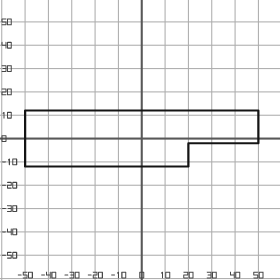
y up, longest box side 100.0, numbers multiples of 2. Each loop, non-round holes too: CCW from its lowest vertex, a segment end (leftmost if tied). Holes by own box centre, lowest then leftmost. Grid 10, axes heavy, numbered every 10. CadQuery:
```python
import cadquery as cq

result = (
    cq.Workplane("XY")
    .moveTo(-50.0, -12.0)
    .lineTo(20.0, -12.0)
    .lineTo(20.0, -2.0)
    .lineTo(50.0, -2.0)
    .lineTo(50.0, 12.0)
    .lineTo(-50.0, 12.0)
    .close()
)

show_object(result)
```